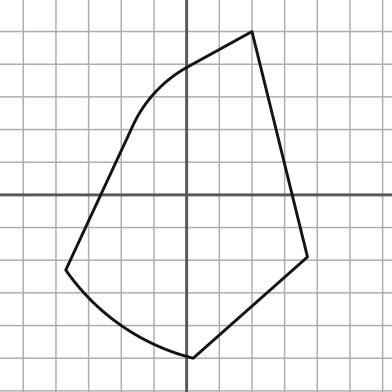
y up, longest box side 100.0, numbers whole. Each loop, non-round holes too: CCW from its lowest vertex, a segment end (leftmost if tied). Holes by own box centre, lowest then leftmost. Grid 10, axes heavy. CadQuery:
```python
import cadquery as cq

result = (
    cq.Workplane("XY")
    .moveTo(2.0, -50.0)
    .lineTo(37.0, -19.0)
    .lineTo(20.0, 50.0)
    .lineTo(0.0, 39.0)
    .threePointArc((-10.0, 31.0), (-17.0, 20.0))
    .lineTo(-37.0, -23.0)
    .threePointArc((-20.0, -40.0), (2.0, -50.0))
    .close()
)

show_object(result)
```